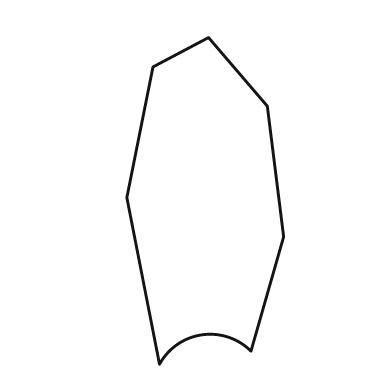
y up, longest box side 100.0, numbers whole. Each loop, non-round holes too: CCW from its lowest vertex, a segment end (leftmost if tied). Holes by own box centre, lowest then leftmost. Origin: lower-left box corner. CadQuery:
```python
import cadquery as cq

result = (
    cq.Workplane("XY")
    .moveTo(10.0, 0.0)
    .threePointArc((23.0, 9.0), (38.0, 4.0))
    .lineTo(48.0, 39.0)
    .lineTo(43.0, 79.0)
    .lineTo(25.0, 100.0)
    .lineTo(8.0, 91.0)
    .lineTo(0.0, 51.0)
    .close()
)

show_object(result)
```